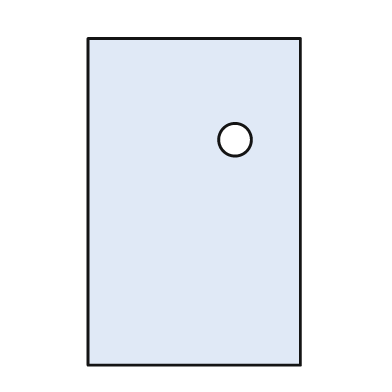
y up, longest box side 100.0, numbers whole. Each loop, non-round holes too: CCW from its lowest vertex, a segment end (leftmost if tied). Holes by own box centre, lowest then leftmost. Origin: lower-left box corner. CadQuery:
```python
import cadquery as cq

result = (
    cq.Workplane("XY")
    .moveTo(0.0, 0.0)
    .lineTo(65.0, 0.0)
    .lineTo(65.0, 100.0)
    .lineTo(0.0, 100.0)
    .close()
    .moveTo(45.0, 69.0)
    .circle(5.0)
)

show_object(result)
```